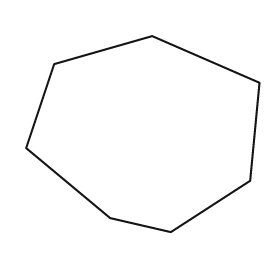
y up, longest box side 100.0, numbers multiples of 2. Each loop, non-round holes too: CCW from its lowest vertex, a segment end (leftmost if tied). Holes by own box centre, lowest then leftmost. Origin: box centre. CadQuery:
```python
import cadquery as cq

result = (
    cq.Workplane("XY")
    .moveTo(12.0, -42.0)
    .lineTo(46.0, -20.0)
    .lineTo(50.0, 22.0)
    .lineTo(4.0, 42.0)
    .lineTo(-38.0, 30.0)
    .lineTo(-50.0, -6.0)
    .lineTo(-14.0, -36.0)
    .close()
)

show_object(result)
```